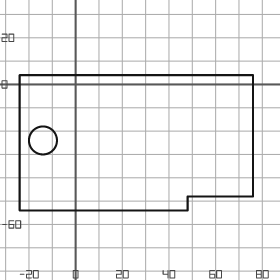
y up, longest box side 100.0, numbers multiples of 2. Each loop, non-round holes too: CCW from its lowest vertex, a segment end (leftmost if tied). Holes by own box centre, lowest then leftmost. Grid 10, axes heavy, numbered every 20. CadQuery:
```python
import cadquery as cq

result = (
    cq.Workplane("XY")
    .moveTo(-24.0, -54.0)
    .lineTo(48.0, -54.0)
    .lineTo(48.0, -48.0)
    .lineTo(76.0, -48.0)
    .lineTo(76.0, 4.0)
    .lineTo(-24.0, 4.0)
    .close()
    .moveTo(-14.0, -24.0)
    .circle(6.0)
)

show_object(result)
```